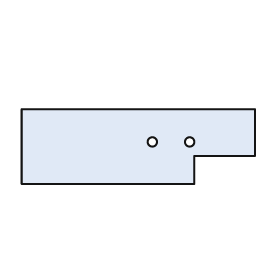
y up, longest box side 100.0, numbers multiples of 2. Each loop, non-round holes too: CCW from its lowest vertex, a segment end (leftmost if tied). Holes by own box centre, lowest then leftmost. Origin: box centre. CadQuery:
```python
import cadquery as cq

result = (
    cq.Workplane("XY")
    .moveTo(-50.0, -16.0)
    .lineTo(24.0, -16.0)
    .lineTo(24.0, -4.0)
    .lineTo(50.0, -4.0)
    .lineTo(50.0, 16.0)
    .lineTo(-50.0, 16.0)
    .close()
    .moveTo(6.0, 2.0)
    .circle(2.0)
    .moveTo(22.0, 2.0)
    .circle(2.0)
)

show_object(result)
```